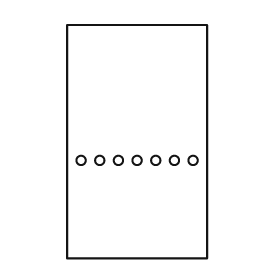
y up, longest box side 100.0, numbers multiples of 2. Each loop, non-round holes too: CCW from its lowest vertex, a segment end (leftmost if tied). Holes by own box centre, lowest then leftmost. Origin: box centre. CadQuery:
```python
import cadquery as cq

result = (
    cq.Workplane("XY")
    .moveTo(-30.0, -50.0)
    .lineTo(30.0, -50.0)
    .lineTo(30.0, 50.0)
    .lineTo(-30.0, 50.0)
    .close()
    .moveTo(-24.0, -8.0)
    .circle(2.0)
    .moveTo(-16.0, -8.0)
    .circle(2.0)
    .moveTo(-8.0, -8.0)
    .circle(2.0)
    .moveTo(0.0, -8.0)
    .circle(2.0)
    .moveTo(8.0, -8.0)
    .circle(2.0)
    .moveTo(16.0, -8.0)
    .circle(2.0)
    .moveTo(24.0, -8.0)
    .circle(2.0)
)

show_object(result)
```